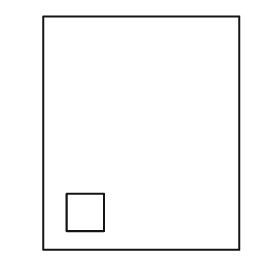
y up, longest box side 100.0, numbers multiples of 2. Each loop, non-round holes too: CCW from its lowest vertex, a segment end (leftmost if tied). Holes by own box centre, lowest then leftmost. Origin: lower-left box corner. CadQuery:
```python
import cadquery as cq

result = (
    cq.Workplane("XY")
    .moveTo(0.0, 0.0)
    .lineTo(84.0, 0.0)
    .lineTo(84.0, 100.0)
    .lineTo(0.0, 100.0)
    .close()
    .moveTo(10.0, 8.0)
    .lineTo(26.0, 8.0)
    .lineTo(26.0, 24.0)
    .lineTo(10.0, 24.0)
    .close()
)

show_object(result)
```